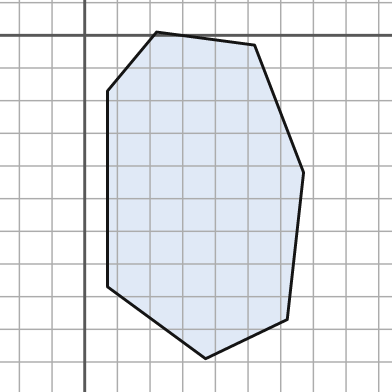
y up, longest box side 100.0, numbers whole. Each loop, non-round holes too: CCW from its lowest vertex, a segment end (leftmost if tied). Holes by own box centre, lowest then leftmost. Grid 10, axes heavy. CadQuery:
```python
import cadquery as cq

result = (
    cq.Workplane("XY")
    .moveTo(37.0, -99.0)
    .lineTo(62.0, -87.0)
    .lineTo(67.0, -42.0)
    .lineTo(52.0, -3.0)
    .lineTo(22.0, 1.0)
    .lineTo(7.0, -17.0)
    .lineTo(7.0, -77.0)
    .close()
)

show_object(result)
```